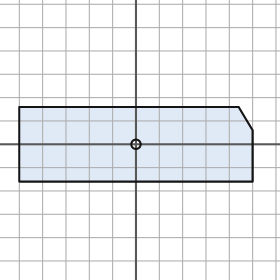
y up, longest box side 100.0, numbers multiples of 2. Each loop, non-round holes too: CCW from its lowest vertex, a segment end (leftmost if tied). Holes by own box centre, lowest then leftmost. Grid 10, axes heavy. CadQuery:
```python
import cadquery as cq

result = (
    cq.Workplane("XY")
    .moveTo(-50.0, -16.0)
    .lineTo(50.0, -16.0)
    .lineTo(50.0, 6.0)
    .lineTo(44.0, 16.0)
    .lineTo(-50.0, 16.0)
    .close()
    .moveTo(0.0, 0.0)
    .circle(2.0)
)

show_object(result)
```